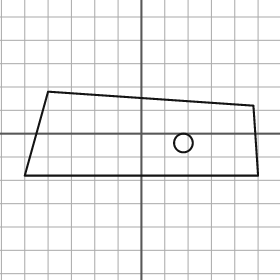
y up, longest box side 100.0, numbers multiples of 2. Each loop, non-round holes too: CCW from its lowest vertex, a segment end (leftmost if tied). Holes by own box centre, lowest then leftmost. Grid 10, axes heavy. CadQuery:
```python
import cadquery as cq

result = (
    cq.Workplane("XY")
    .moveTo(-50.0, -18.0)
    .lineTo(50.0, -18.0)
    .lineTo(48.0, 12.0)
    .lineTo(-40.0, 18.0)
    .close()
    .moveTo(18.0, -4.0)
    .circle(4.0)
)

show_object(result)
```